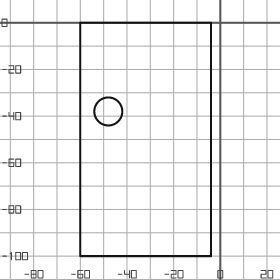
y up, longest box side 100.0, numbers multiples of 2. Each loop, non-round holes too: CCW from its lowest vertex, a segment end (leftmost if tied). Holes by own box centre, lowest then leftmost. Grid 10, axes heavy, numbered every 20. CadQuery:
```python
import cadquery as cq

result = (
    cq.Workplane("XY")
    .moveTo(-60.0, -100.0)
    .lineTo(-4.0, -100.0)
    .lineTo(-4.0, 0.0)
    .lineTo(-60.0, 0.0)
    .close()
    .moveTo(-48.0, -38.0)
    .circle(6.0)
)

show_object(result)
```